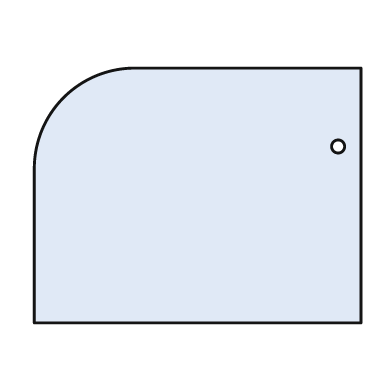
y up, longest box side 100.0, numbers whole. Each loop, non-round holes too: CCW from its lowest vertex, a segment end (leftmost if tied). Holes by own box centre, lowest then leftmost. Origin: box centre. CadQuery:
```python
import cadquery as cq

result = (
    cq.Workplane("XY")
    .moveTo(-50.0, -39.0)
    .lineTo(50.0, -39.0)
    .lineTo(50.0, 39.0)
    .lineTo(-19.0, 39.0)
    .threePointArc((-41.0, 30.0), (-50.0, 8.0))
    .close()
    .moveTo(43.0, 15.0)
    .circle(2.0)
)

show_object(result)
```